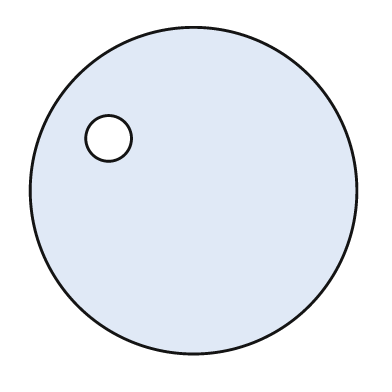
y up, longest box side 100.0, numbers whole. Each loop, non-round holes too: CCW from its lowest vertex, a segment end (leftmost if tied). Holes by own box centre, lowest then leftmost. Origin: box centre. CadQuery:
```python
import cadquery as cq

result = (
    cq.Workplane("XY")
    .moveTo(0.0, 0.0)
    .circle(50.0)
    .moveTo(-26.0, 16.0)
    .circle(7.0)
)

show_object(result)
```